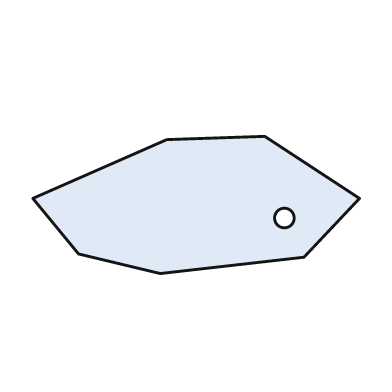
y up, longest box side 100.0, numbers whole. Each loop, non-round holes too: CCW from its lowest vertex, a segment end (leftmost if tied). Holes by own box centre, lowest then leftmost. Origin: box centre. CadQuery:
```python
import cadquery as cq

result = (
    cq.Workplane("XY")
    .moveTo(-11.0, -21.0)
    .lineTo(33.0, -16.0)
    .lineTo(50.0, 2.0)
    .lineTo(21.0, 21.0)
    .lineTo(-9.0, 20.0)
    .lineTo(-50.0, 2.0)
    .lineTo(-36.0, -15.0)
    .close()
    .moveTo(27.0, -4.0)
    .circle(3.0)
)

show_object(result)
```